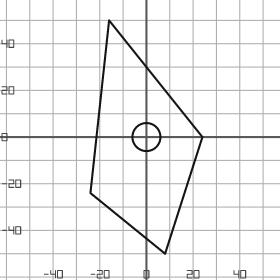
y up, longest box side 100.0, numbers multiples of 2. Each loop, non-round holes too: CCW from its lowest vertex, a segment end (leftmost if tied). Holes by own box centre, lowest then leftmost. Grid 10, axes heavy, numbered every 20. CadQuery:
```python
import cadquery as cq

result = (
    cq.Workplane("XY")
    .moveTo(8.0, -50.0)
    .lineTo(24.0, 0.0)
    .lineTo(-16.0, 50.0)
    .lineTo(-24.0, -24.0)
    .close()
    .moveTo(0.0, 0.0)
    .circle(6.0)
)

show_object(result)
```